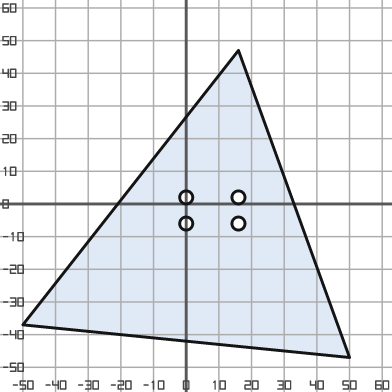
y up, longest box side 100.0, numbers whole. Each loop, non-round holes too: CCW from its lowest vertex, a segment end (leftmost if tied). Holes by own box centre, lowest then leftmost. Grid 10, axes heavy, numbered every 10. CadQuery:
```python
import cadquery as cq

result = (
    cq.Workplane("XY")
    .moveTo(50.0, -47.0)
    .lineTo(16.0, 47.0)
    .lineTo(-50.0, -37.0)
    .close()
    .moveTo(0.0, -6.0)
    .circle(2.0)
    .moveTo(16.0, -6.0)
    .circle(2.0)
    .moveTo(0.0, 2.0)
    .circle(2.0)
    .moveTo(16.0, 2.0)
    .circle(2.0)
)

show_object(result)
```